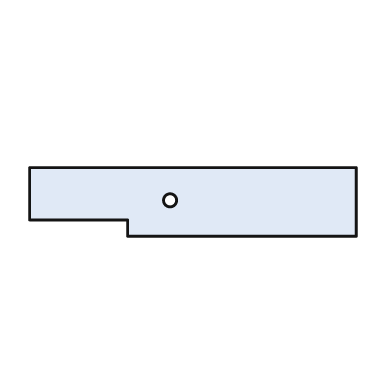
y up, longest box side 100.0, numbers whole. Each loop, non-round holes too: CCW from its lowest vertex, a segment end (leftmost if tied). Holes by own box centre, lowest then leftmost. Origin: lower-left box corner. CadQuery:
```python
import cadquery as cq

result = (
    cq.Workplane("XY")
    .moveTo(30.0, 0.0)
    .lineTo(100.0, 0.0)
    .lineTo(100.0, 21.0)
    .lineTo(0.0, 21.0)
    .lineTo(0.0, 5.0)
    .lineTo(30.0, 5.0)
    .close()
    .moveTo(43.0, 11.0)
    .circle(2.0)
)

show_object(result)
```